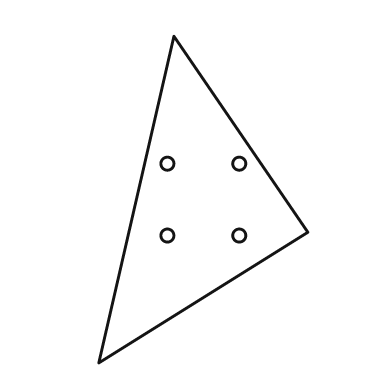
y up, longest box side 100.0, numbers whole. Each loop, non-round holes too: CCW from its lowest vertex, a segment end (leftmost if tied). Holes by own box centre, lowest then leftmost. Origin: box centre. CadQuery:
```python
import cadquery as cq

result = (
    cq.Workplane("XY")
    .moveTo(-32.0, -50.0)
    .lineTo(32.0, -10.0)
    .lineTo(-9.0, 50.0)
    .close()
    .moveTo(-11.0, -11.0)
    .circle(2.0)
    .moveTo(11.0, -11.0)
    .circle(2.0)
    .moveTo(-11.0, 11.0)
    .circle(2.0)
    .moveTo(11.0, 11.0)
    .circle(2.0)
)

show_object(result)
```